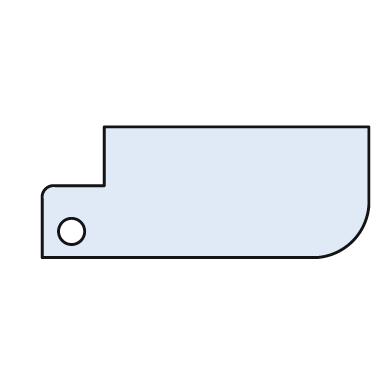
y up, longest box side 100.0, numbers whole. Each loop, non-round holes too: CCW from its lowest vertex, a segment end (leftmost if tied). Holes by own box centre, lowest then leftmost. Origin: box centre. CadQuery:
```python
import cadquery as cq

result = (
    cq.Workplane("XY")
    .moveTo(-50.0, -20.0)
    .lineTo(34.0, -20.0)
    .threePointArc((45.0, -15.0), (50.0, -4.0))
    .lineTo(50.0, 20.0)
    .lineTo(-31.0, 20.0)
    .lineTo(-31.0, 2.0)
    .lineTo(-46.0, 2.0)
    .threePointArc((-49.0, 1.0), (-50.0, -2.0))
    .close()
    .moveTo(-41.0, -12.0)
    .circle(4.0)
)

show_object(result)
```